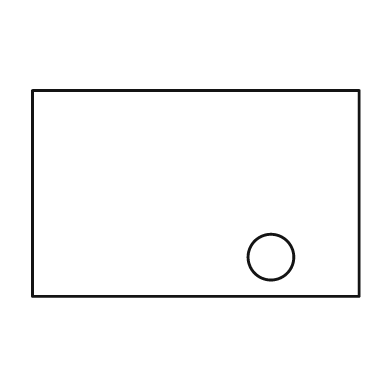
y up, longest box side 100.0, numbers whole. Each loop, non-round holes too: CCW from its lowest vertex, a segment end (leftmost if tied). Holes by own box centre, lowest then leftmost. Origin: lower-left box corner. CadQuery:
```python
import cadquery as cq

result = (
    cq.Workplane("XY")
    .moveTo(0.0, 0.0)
    .lineTo(100.0, 0.0)
    .lineTo(100.0, 63.0)
    .lineTo(0.0, 63.0)
    .close()
    .moveTo(73.0, 12.0)
    .circle(7.0)
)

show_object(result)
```